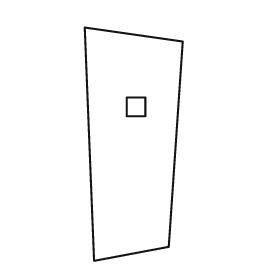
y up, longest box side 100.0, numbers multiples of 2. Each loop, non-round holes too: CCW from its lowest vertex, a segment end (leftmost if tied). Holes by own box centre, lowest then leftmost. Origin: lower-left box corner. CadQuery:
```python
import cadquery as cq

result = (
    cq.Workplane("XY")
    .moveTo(4.0, 0.0)
    .lineTo(36.0, 6.0)
    .lineTo(42.0, 94.0)
    .lineTo(0.0, 100.0)
    .close()
    .moveTo(18.0, 62.0)
    .lineTo(26.0, 62.0)
    .lineTo(26.0, 70.0)
    .lineTo(18.0, 70.0)
    .close()
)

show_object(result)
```